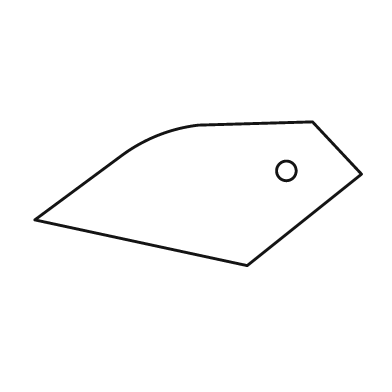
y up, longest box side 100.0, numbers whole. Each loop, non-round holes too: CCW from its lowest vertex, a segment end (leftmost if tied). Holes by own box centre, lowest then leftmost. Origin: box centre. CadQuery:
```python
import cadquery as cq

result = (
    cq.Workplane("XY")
    .moveTo(15.0, -22.0)
    .lineTo(50.0, 6.0)
    .lineTo(35.0, 22.0)
    .lineTo(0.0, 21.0)
    .threePointArc((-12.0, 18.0), (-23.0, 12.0))
    .lineTo(-50.0, -8.0)
    .close()
    .moveTo(27.0, 7.0)
    .circle(3.0)
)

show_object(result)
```